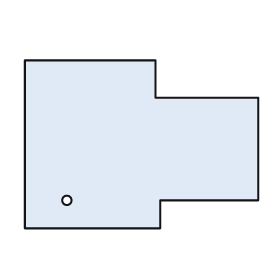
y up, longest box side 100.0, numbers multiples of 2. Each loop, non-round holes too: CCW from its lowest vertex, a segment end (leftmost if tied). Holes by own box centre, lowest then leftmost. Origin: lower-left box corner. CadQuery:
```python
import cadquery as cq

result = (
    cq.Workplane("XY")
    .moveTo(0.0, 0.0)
    .lineTo(58.0, 0.0)
    .lineTo(58.0, 12.0)
    .lineTo(100.0, 12.0)
    .lineTo(100.0, 56.0)
    .lineTo(56.0, 56.0)
    .lineTo(56.0, 72.0)
    .lineTo(0.0, 72.0)
    .close()
    .moveTo(18.0, 12.0)
    .circle(2.0)
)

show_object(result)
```